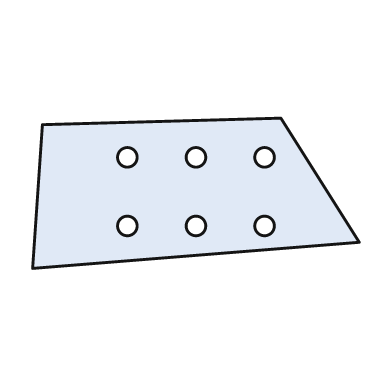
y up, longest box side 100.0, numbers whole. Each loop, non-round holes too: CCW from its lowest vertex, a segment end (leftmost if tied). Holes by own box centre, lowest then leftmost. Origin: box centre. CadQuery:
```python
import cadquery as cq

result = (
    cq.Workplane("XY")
    .moveTo(-50.0, -23.0)
    .lineTo(50.0, -15.0)
    .lineTo(26.0, 23.0)
    .lineTo(-47.0, 21.0)
    .close()
    .moveTo(-21.0, -10.0)
    .circle(3.0)
    .moveTo(0.0, -10.0)
    .circle(3.0)
    .moveTo(21.0, -10.0)
    .circle(3.0)
    .moveTo(-21.0, 11.0)
    .circle(3.0)
    .moveTo(0.0, 11.0)
    .circle(3.0)
    .moveTo(21.0, 11.0)
    .circle(3.0)
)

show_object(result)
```